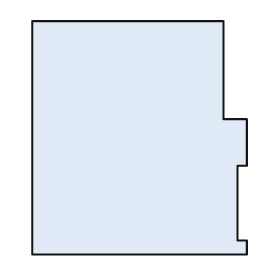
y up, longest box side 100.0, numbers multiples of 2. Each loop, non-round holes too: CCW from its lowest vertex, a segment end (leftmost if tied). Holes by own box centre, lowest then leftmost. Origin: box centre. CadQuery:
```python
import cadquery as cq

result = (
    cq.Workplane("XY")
    .moveTo(-46.0, -50.0)
    .lineTo(46.0, -50.0)
    .lineTo(46.0, -44.0)
    .lineTo(42.0, -44.0)
    .lineTo(42.0, -12.0)
    .lineTo(46.0, -12.0)
    .lineTo(46.0, 8.0)
    .lineTo(36.0, 8.0)
    .lineTo(36.0, 50.0)
    .lineTo(-46.0, 50.0)
    .close()
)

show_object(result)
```